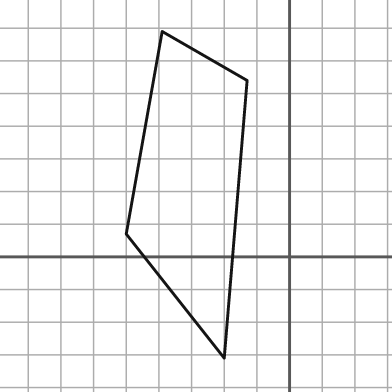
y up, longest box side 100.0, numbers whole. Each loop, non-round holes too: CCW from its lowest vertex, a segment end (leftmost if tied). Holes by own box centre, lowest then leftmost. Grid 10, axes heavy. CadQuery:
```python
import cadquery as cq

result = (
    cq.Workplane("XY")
    .moveTo(-20.0, -31.0)
    .lineTo(-13.0, 54.0)
    .lineTo(-39.0, 69.0)
    .lineTo(-50.0, 7.0)
    .close()
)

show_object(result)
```